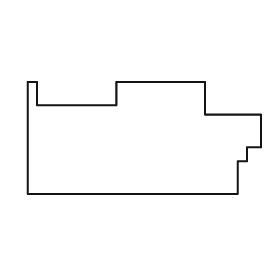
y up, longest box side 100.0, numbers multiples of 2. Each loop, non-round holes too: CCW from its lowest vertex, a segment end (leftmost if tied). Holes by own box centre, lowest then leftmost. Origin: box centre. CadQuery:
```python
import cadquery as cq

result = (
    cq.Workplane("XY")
    .moveTo(-50.0, -24.0)
    .lineTo(40.0, -24.0)
    .lineTo(40.0, -10.0)
    .lineTo(44.0, -10.0)
    .lineTo(44.0, -4.0)
    .lineTo(50.0, -4.0)
    .lineTo(50.0, 10.0)
    .lineTo(26.0, 10.0)
    .lineTo(26.0, 24.0)
    .lineTo(-12.0, 24.0)
    .lineTo(-12.0, 14.0)
    .lineTo(-46.0, 14.0)
    .lineTo(-46.0, 24.0)
    .lineTo(-50.0, 24.0)
    .close()
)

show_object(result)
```